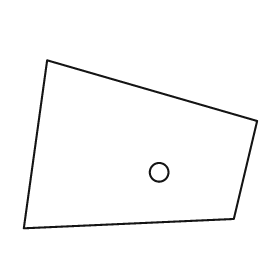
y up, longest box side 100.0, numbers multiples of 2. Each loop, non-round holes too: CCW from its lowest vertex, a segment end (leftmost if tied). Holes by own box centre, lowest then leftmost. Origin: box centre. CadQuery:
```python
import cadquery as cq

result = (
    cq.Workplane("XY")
    .moveTo(-50.0, -36.0)
    .lineTo(40.0, -32.0)
    .lineTo(50.0, 10.0)
    .lineTo(-40.0, 36.0)
    .close()
    .moveTo(8.0, -12.0)
    .circle(4.0)
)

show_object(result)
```